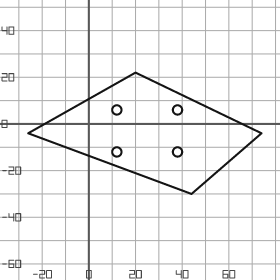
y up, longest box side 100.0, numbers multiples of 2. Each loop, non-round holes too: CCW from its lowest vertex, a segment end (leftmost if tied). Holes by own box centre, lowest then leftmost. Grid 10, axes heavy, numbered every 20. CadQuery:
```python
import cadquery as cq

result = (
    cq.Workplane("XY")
    .moveTo(44.0, -30.0)
    .lineTo(74.0, -4.0)
    .lineTo(20.0, 22.0)
    .lineTo(-26.0, -4.0)
    .close()
    .moveTo(12.0, -12.0)
    .circle(2.0)
    .moveTo(38.0, -12.0)
    .circle(2.0)
    .moveTo(12.0, 6.0)
    .circle(2.0)
    .moveTo(38.0, 6.0)
    .circle(2.0)
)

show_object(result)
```